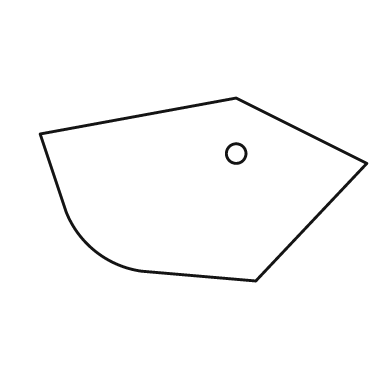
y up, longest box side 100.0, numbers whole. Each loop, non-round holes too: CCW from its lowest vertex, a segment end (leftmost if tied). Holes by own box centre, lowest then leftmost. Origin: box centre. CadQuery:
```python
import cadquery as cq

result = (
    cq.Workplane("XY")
    .moveTo(16.0, -28.0)
    .lineTo(50.0, 8.0)
    .lineTo(10.0, 28.0)
    .lineTo(-50.0, 17.0)
    .lineTo(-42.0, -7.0)
    .threePointArc((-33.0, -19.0), (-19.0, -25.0))
    .close()
    .moveTo(10.0, 11.0)
    .circle(3.0)
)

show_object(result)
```